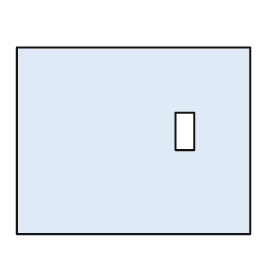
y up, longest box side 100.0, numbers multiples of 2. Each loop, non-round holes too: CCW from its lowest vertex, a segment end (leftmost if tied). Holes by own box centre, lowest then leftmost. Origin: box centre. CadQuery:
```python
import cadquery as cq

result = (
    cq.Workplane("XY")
    .moveTo(-50.0, -40.0)
    .lineTo(50.0, -40.0)
    .lineTo(50.0, 40.0)
    .lineTo(-50.0, 40.0)
    .close()
    .moveTo(18.0, -4.0)
    .lineTo(26.0, -4.0)
    .lineTo(26.0, 12.0)
    .lineTo(18.0, 12.0)
    .close()
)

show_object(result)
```